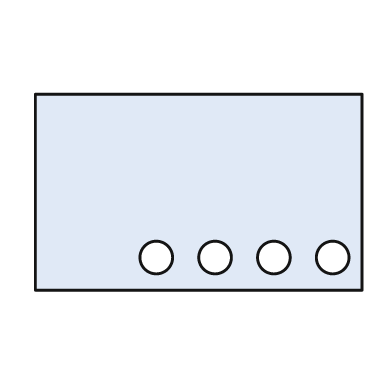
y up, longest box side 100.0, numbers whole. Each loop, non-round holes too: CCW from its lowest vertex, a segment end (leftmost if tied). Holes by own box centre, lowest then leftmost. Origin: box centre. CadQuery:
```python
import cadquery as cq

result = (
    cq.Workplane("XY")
    .moveTo(-50.0, -30.0)
    .lineTo(50.0, -30.0)
    .lineTo(50.0, 30.0)
    .lineTo(-50.0, 30.0)
    .close()
    .moveTo(-13.0, -20.0)
    .circle(5.0)
    .moveTo(5.0, -20.0)
    .circle(5.0)
    .moveTo(23.0, -20.0)
    .circle(5.0)
    .moveTo(41.0, -20.0)
    .circle(5.0)
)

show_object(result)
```